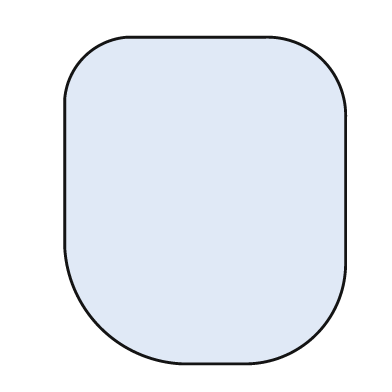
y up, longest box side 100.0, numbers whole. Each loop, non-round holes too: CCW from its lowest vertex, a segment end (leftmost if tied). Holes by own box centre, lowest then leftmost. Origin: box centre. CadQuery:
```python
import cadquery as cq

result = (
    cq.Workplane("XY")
    .moveTo(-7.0, -50.0)
    .lineTo(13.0, -50.0)
    .threePointArc((34.0, -41.0), (43.0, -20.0))
    .lineTo(43.0, 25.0)
    .threePointArc((36.0, 43.0), (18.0, 50.0))
    .lineTo(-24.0, 50.0)
    .threePointArc((-37.0, 44.0), (-43.0, 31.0))
    .lineTo(-43.0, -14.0)
    .threePointArc((-32.0, -39.0), (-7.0, -50.0))
    .close()
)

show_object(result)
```